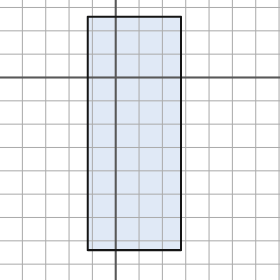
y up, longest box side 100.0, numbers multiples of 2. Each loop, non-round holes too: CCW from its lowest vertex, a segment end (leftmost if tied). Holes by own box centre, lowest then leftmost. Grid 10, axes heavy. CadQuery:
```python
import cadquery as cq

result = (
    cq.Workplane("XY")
    .moveTo(-12.0, -74.0)
    .lineTo(28.0, -74.0)
    .lineTo(28.0, 26.0)
    .lineTo(-12.0, 26.0)
    .close()
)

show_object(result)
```